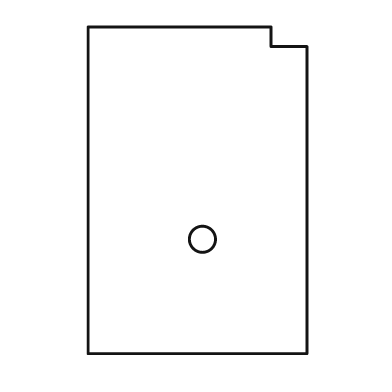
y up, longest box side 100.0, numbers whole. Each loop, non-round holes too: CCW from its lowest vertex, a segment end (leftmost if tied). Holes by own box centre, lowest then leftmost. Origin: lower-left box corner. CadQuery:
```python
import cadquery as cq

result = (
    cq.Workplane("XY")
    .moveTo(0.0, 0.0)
    .lineTo(67.0, 0.0)
    .lineTo(67.0, 94.0)
    .lineTo(56.0, 94.0)
    .lineTo(56.0, 100.0)
    .lineTo(0.0, 100.0)
    .close()
    .moveTo(35.0, 35.0)
    .circle(4.0)
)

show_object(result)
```